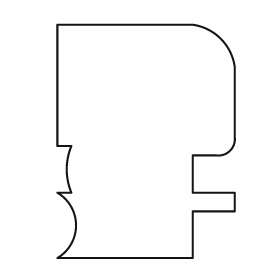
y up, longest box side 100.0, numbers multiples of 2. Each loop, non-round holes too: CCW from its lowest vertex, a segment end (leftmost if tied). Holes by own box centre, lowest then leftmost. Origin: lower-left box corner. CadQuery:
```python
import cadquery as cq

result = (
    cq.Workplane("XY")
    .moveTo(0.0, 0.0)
    .lineTo(58.0, 0.0)
    .lineTo(58.0, 20.0)
    .lineTo(76.0, 20.0)
    .lineTo(76.0, 28.0)
    .lineTo(58.0, 28.0)
    .lineTo(58.0, 44.0)
    .lineTo(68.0, 44.0)
    .threePointArc((74.0, 46.0), (76.0, 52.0))
    .lineTo(76.0, 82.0)
    .threePointArc((70.0, 94.0), (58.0, 100.0))
    .lineTo(0.0, 100.0)
    .lineTo(0.0, 48.0)
    .lineTo(6.0, 48.0)
    .threePointArc((4.0, 38.0), (6.0, 28.0))
    .lineTo(0.0, 28.0)
    .threePointArc((8.0, 14.0), (0.0, 0.0))
    .close()
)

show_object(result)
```